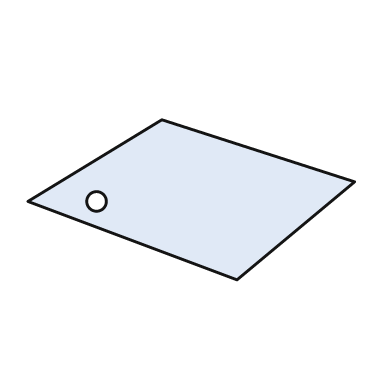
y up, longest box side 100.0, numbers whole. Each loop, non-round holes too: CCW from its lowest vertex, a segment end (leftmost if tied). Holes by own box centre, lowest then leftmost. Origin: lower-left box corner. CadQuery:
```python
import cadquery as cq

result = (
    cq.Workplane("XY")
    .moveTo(64.0, 0.0)
    .lineTo(100.0, 30.0)
    .lineTo(41.0, 49.0)
    .lineTo(0.0, 24.0)
    .close()
    .moveTo(21.0, 24.0)
    .circle(3.0)
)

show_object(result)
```